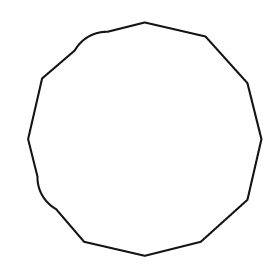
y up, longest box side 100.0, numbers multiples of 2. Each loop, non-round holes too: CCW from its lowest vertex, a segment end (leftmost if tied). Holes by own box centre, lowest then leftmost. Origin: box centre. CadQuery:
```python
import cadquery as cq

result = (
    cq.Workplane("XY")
    .moveTo(0.0, -50.0)
    .lineTo(24.0, -44.0)
    .lineTo(44.0, -26.0)
    .lineTo(50.0, 0.0)
    .lineTo(44.0, 24.0)
    .lineTo(26.0, 44.0)
    .lineTo(0.0, 50.0)
    .lineTo(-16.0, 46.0)
    .threePointArc((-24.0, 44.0), (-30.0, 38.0))
    .lineTo(-44.0, 26.0)
    .lineTo(-50.0, 0.0)
    .lineTo(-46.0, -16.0)
    .threePointArc((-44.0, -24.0), (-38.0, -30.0))
    .lineTo(-26.0, -44.0)
    .close()
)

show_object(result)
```